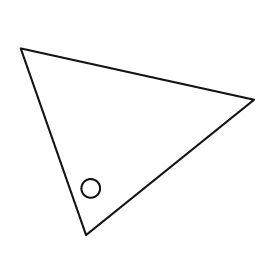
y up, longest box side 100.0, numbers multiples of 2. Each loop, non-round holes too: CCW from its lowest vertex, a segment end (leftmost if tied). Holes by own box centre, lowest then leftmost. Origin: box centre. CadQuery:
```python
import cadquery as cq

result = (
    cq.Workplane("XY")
    .moveTo(-22.0, -40.0)
    .lineTo(50.0, 18.0)
    .lineTo(-50.0, 40.0)
    .close()
    .moveTo(-20.0, -20.0)
    .circle(4.0)
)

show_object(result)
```